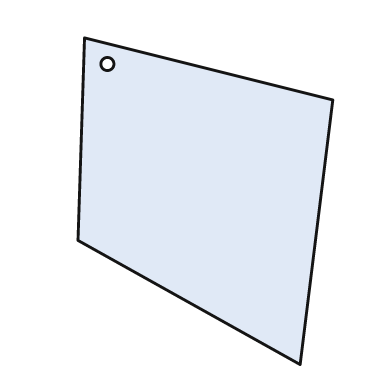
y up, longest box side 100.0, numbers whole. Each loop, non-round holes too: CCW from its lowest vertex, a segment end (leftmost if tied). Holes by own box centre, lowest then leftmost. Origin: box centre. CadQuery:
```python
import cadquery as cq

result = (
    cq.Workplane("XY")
    .moveTo(29.0, -50.0)
    .lineTo(39.0, 31.0)
    .lineTo(-37.0, 50.0)
    .lineTo(-39.0, -12.0)
    .close()
    .moveTo(-30.0, 42.0)
    .circle(2.0)
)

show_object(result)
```